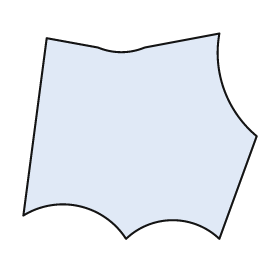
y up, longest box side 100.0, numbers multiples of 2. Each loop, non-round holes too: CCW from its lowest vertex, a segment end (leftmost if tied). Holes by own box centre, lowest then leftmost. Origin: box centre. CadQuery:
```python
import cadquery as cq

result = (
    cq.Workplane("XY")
    .moveTo(-6.0, -44.0)
    .threePointArc((14.0, -36.0), (34.0, -44.0))
    .lineTo(50.0, 0.0)
    .threePointArc((36.0, 20.0), (34.0, 44.0))
    .lineTo(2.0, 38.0)
    .threePointArc((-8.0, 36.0), (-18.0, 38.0))
    .lineTo(-40.0, 42.0)
    .lineTo(-50.0, -34.0)
    .threePointArc((-26.0, -30.0), (-6.0, -44.0))
    .close()
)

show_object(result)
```